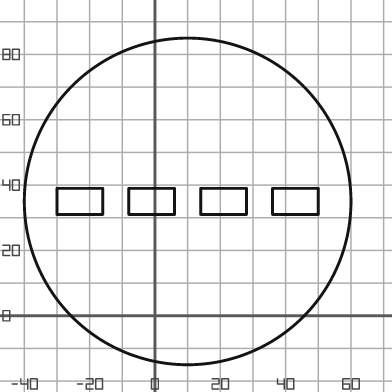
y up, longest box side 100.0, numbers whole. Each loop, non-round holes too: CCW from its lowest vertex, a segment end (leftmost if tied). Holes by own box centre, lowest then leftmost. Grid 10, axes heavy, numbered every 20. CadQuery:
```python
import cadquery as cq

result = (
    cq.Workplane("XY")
    .moveTo(10.0, 35.0)
    .circle(50.0)
    .moveTo(-30.0, 31.0)
    .lineTo(-16.0, 31.0)
    .lineTo(-16.0, 39.0)
    .lineTo(-30.0, 39.0)
    .close()
    .moveTo(-8.0, 31.0)
    .lineTo(6.0, 31.0)
    .lineTo(6.0, 39.0)
    .lineTo(-8.0, 39.0)
    .close()
    .moveTo(14.0, 31.0)
    .lineTo(28.0, 31.0)
    .lineTo(28.0, 39.0)
    .lineTo(14.0, 39.0)
    .close()
    .moveTo(36.0, 31.0)
    .lineTo(50.0, 31.0)
    .lineTo(50.0, 39.0)
    .lineTo(36.0, 39.0)
    .close()
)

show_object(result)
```